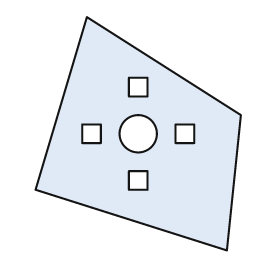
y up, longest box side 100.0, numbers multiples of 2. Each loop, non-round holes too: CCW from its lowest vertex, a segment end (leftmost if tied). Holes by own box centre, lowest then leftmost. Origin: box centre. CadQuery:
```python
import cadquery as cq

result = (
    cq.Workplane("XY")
    .moveTo(38.0, -50.0)
    .lineTo(44.0, 8.0)
    .lineTo(-22.0, 50.0)
    .lineTo(-44.0, -24.0)
    .close()
    .moveTo(-4.0, -24.0)
    .lineTo(4.0, -24.0)
    .lineTo(4.0, -16.0)
    .lineTo(-4.0, -16.0)
    .close()
    .moveTo(-24.0, -4.0)
    .lineTo(-16.0, -4.0)
    .lineTo(-16.0, 4.0)
    .lineTo(-24.0, 4.0)
    .close()
    .moveTo(0.0, 0.0)
    .circle(8.0)
    .moveTo(16.0, -4.0)
    .lineTo(24.0, -4.0)
    .lineTo(24.0, 4.0)
    .lineTo(16.0, 4.0)
    .close()
    .moveTo(-4.0, 16.0)
    .lineTo(4.0, 16.0)
    .lineTo(4.0, 24.0)
    .lineTo(-4.0, 24.0)
    .close()
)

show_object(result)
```